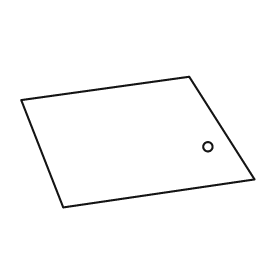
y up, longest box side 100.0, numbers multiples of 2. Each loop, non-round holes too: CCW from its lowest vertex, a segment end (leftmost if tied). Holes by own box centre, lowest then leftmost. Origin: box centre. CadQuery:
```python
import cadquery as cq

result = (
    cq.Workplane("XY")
    .moveTo(-32.0, -28.0)
    .lineTo(50.0, -16.0)
    .lineTo(22.0, 28.0)
    .lineTo(-50.0, 18.0)
    .close()
    .moveTo(30.0, -2.0)
    .circle(2.0)
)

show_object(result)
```